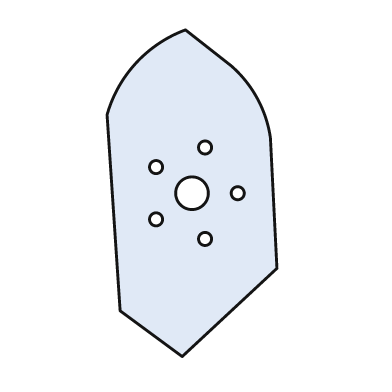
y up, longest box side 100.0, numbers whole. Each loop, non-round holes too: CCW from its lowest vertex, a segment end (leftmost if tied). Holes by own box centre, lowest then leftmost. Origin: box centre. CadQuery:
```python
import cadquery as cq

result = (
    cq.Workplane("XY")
    .moveTo(-3.0, -50.0)
    .lineTo(26.0, -23.0)
    .lineTo(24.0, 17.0)
    .threePointArc((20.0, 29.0), (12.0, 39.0))
    .lineTo(-2.0, 50.0)
    .threePointArc((-17.0, 40.0), (-26.0, 24.0))
    .lineTo(-22.0, -36.0)
    .close()
    .moveTo(4.0, -14.0)
    .circle(2.0)
    .moveTo(-11.0, -8.0)
    .circle(2.0)
    .moveTo(0.0, 0.0)
    .circle(5.0)
    .moveTo(14.0, 0.0)
    .circle(2.0)
    .moveTo(-11.0, 8.0)
    .circle(2.0)
    .moveTo(4.0, 14.0)
    .circle(2.0)
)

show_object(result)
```